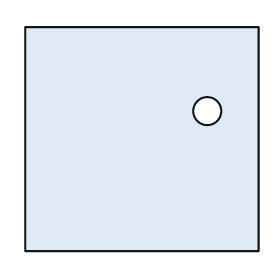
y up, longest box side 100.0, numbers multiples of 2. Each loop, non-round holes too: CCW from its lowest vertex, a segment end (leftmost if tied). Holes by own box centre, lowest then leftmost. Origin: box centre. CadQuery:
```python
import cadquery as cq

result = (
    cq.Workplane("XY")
    .moveTo(-50.0, -48.0)
    .lineTo(50.0, -48.0)
    .lineTo(50.0, 48.0)
    .lineTo(-50.0, 48.0)
    .close()
    .moveTo(28.0, 12.0)
    .circle(6.0)
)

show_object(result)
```